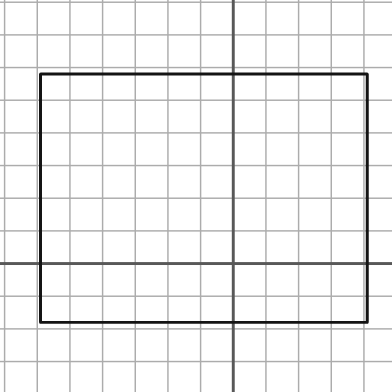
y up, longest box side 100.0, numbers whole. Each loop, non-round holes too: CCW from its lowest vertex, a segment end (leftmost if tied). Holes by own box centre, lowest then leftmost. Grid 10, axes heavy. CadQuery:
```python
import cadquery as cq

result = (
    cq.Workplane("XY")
    .moveTo(-59.0, -18.0)
    .lineTo(41.0, -18.0)
    .lineTo(41.0, 58.0)
    .lineTo(-59.0, 58.0)
    .close()
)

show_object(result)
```